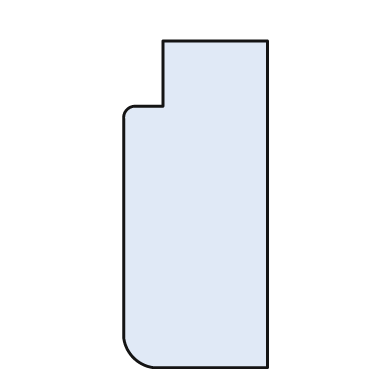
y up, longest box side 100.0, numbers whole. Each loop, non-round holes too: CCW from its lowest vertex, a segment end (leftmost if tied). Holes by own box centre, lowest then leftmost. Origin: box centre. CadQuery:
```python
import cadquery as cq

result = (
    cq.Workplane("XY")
    .moveTo(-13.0, -50.0)
    .lineTo(22.0, -50.0)
    .lineTo(22.0, 50.0)
    .lineTo(-10.0, 50.0)
    .lineTo(-10.0, 30.0)
    .lineTo(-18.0, 30.0)
    .threePointArc((-21.0, 29.0), (-22.0, 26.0))
    .lineTo(-22.0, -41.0)
    .threePointArc((-19.0, -47.0), (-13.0, -50.0))
    .close()
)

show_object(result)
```